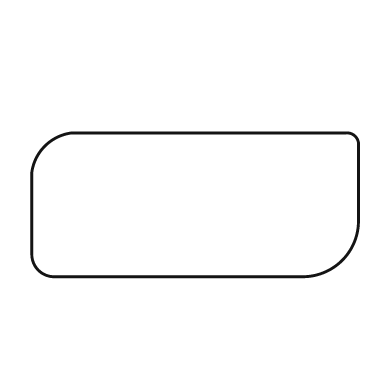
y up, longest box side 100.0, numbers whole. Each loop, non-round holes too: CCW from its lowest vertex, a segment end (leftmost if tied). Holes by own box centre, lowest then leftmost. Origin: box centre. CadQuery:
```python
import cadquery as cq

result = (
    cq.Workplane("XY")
    .moveTo(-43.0, -22.0)
    .lineTo(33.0, -22.0)
    .threePointArc((45.0, -17.0), (50.0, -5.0))
    .lineTo(50.0, 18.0)
    .threePointArc((49.0, 21.0), (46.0, 22.0))
    .lineTo(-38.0, 22.0)
    .threePointArc((-46.0, 18.0), (-50.0, 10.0))
    .lineTo(-50.0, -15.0)
    .threePointArc((-48.0, -20.0), (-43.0, -22.0))
    .close()
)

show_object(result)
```